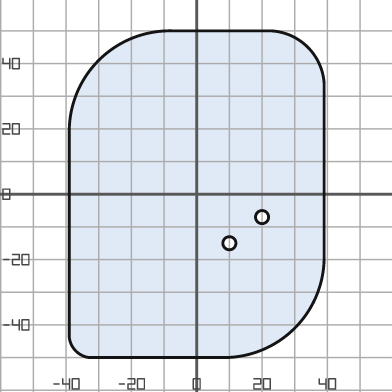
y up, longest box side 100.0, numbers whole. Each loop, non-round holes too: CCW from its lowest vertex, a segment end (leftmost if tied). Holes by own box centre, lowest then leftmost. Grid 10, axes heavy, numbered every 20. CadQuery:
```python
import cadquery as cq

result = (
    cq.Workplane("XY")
    .moveTo(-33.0, -50.0)
    .lineTo(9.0, -50.0)
    .threePointArc((30.0, -41.0), (39.0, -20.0))
    .lineTo(39.0, 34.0)
    .threePointArc((34.0, 45.0), (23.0, 50.0))
    .lineTo(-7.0, 50.0)
    .threePointArc((-30.0, 41.0), (-39.0, 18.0))
    .lineTo(-39.0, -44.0)
    .threePointArc((-37.0, -48.0), (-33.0, -50.0))
    .close()
    .moveTo(10.0, -15.0)
    .circle(2.0)
    .moveTo(20.0, -7.0)
    .circle(2.0)
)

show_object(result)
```